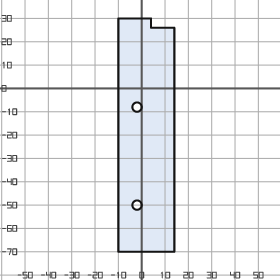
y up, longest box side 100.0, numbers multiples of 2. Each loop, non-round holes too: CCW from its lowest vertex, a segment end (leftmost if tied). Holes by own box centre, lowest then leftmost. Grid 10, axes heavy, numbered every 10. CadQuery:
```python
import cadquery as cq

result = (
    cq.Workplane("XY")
    .moveTo(-10.0, -70.0)
    .lineTo(14.0, -70.0)
    .lineTo(14.0, 26.0)
    .lineTo(4.0, 26.0)
    .lineTo(4.0, 30.0)
    .lineTo(-10.0, 30.0)
    .close()
    .moveTo(-2.0, -50.0)
    .circle(2.0)
    .moveTo(-2.0, -8.0)
    .circle(2.0)
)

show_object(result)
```